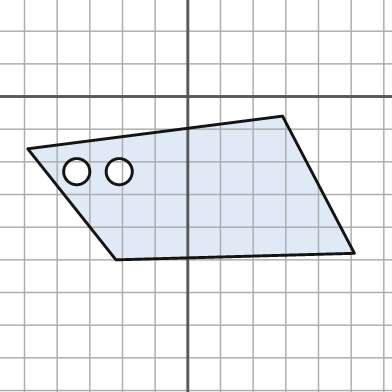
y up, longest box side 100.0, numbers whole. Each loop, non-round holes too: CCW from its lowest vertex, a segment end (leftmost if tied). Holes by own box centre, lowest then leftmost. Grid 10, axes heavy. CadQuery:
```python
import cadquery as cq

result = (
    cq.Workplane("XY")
    .moveTo(-22.0, -50.0)
    .lineTo(51.0, -48.0)
    .lineTo(29.0, -6.0)
    .lineTo(-49.0, -16.0)
    .close()
    .moveTo(-34.0, -23.0)
    .circle(4.0)
    .moveTo(-21.0, -23.0)
    .circle(4.0)
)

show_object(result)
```